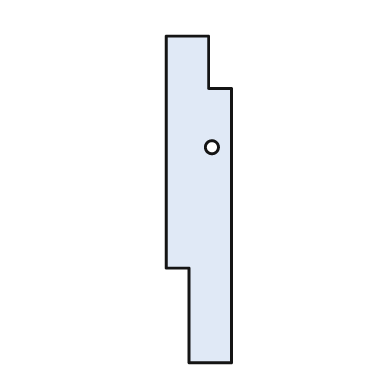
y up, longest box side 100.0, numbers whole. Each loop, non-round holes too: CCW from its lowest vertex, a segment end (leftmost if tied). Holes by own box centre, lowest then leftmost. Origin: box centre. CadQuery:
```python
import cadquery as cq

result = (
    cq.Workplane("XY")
    .moveTo(-3.0, -50.0)
    .lineTo(10.0, -50.0)
    .lineTo(10.0, 34.0)
    .lineTo(3.0, 34.0)
    .lineTo(3.0, 50.0)
    .lineTo(-10.0, 50.0)
    .lineTo(-10.0, -21.0)
    .lineTo(-3.0, -21.0)
    .close()
    .moveTo(4.0, 16.0)
    .circle(2.0)
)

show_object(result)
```